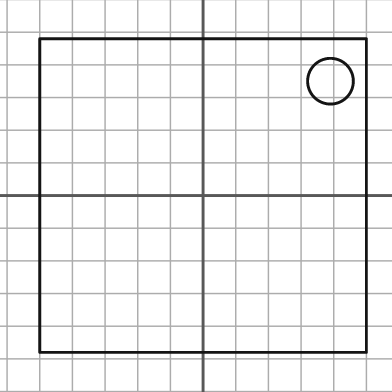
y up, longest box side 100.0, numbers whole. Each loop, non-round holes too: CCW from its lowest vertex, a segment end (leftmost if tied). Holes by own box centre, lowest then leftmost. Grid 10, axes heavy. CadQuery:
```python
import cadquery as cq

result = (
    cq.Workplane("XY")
    .moveTo(-50.0, -48.0)
    .lineTo(50.0, -48.0)
    .lineTo(50.0, 48.0)
    .lineTo(-50.0, 48.0)
    .close()
    .moveTo(39.0, 35.0)
    .circle(7.0)
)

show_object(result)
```